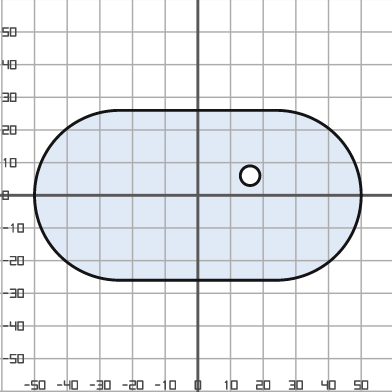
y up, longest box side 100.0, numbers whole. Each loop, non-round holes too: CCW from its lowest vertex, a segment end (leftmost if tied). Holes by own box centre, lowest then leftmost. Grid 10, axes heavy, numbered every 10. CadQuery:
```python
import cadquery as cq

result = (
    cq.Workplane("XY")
    .moveTo(-24.0, -26.0)
    .lineTo(24.0, -26.0)
    .threePointArc((50.0, 0.0), (24.0, 26.0))
    .lineTo(-24.0, 26.0)
    .threePointArc((-50.0, 0.0), (-24.0, -26.0))
    .close()
    .moveTo(16.0, 6.0)
    .circle(3.0)
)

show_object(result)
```